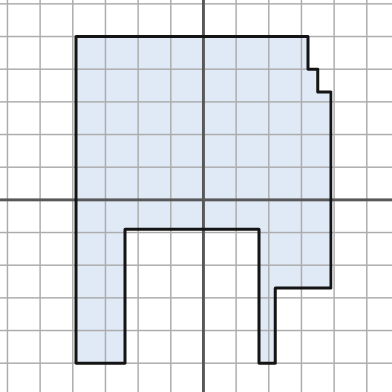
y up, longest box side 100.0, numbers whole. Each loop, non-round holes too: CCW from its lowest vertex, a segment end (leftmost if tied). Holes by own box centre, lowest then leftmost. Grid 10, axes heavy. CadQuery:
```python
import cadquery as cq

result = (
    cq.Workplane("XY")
    .moveTo(-39.0, -50.0)
    .lineTo(-24.0, -50.0)
    .lineTo(-24.0, -9.0)
    .lineTo(17.0, -9.0)
    .lineTo(17.0, -50.0)
    .lineTo(22.0, -50.0)
    .lineTo(22.0, -27.0)
    .lineTo(39.0, -27.0)
    .lineTo(39.0, 33.0)
    .lineTo(35.0, 33.0)
    .lineTo(35.0, 40.0)
    .lineTo(32.0, 40.0)
    .lineTo(32.0, 50.0)
    .lineTo(-39.0, 50.0)
    .close()
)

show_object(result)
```